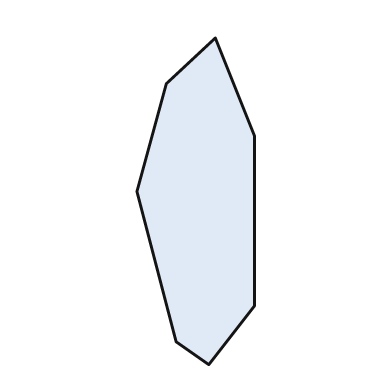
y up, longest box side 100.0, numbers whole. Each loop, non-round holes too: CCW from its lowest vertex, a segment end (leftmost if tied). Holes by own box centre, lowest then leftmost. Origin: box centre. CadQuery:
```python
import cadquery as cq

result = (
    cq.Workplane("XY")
    .moveTo(4.0, -50.0)
    .lineTo(18.0, -32.0)
    .lineTo(18.0, 20.0)
    .lineTo(6.0, 50.0)
    .lineTo(-9.0, 36.0)
    .lineTo(-18.0, 3.0)
    .lineTo(-6.0, -43.0)
    .close()
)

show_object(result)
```